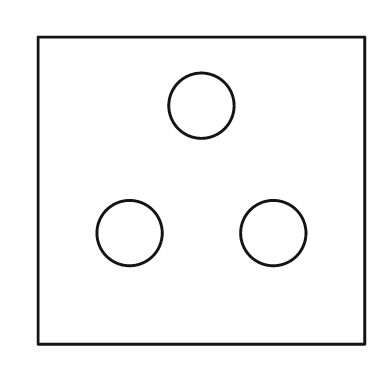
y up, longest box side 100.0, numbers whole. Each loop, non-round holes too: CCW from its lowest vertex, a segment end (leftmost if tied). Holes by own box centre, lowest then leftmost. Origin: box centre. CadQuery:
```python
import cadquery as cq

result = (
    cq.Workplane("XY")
    .moveTo(-50.0, -47.0)
    .lineTo(50.0, -47.0)
    .lineTo(50.0, 47.0)
    .lineTo(-50.0, 47.0)
    .close()
    .moveTo(-22.0, -13.0)
    .circle(10.0)
    .moveTo(22.0, -13.0)
    .circle(10.0)
    .moveTo(0.0, 26.0)
    .circle(10.0)
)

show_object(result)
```